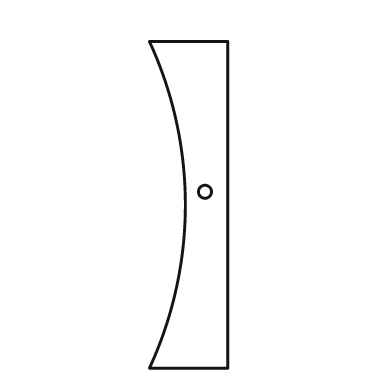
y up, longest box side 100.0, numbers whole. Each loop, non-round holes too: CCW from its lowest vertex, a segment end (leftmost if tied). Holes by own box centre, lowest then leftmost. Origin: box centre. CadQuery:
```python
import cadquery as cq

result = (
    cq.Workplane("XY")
    .moveTo(-12.0, -50.0)
    .lineTo(12.0, -50.0)
    .lineTo(12.0, 50.0)
    .lineTo(-12.0, 50.0)
    .threePointArc((-1.0, 0.0), (-12.0, -50.0))
    .close()
    .moveTo(5.0, 4.0)
    .circle(2.0)
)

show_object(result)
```